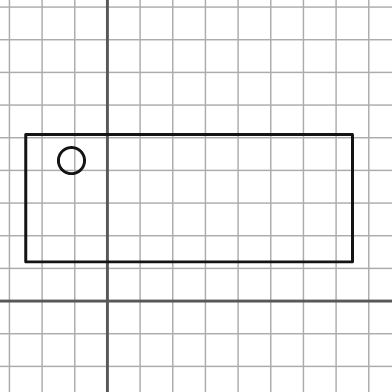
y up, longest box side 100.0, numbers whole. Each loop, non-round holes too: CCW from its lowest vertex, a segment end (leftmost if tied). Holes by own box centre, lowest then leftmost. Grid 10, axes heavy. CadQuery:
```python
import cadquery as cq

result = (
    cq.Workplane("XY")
    .moveTo(-25.0, 12.0)
    .lineTo(75.0, 12.0)
    .lineTo(75.0, 51.0)
    .lineTo(-25.0, 51.0)
    .close()
    .moveTo(-11.0, 43.0)
    .circle(4.0)
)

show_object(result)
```